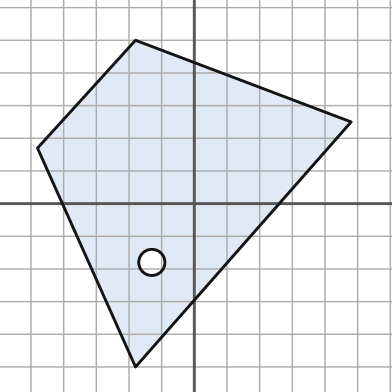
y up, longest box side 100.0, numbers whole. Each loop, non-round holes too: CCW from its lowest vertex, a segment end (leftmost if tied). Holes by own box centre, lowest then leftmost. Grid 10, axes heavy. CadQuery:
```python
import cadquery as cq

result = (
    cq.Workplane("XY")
    .moveTo(-18.0, -50.0)
    .lineTo(48.0, 25.0)
    .lineTo(-18.0, 50.0)
    .lineTo(-48.0, 17.0)
    .close()
    .moveTo(-13.0, -18.0)
    .circle(4.0)
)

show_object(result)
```